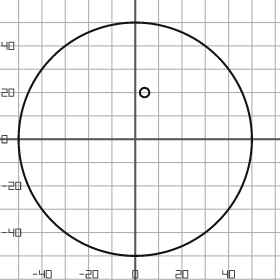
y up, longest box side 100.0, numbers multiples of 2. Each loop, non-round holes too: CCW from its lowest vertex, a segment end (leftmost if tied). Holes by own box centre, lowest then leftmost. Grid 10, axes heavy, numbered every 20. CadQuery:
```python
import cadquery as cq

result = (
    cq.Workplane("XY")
    .moveTo(0.0, 0.0)
    .circle(50.0)
    .moveTo(4.0, 20.0)
    .circle(2.0)
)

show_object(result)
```